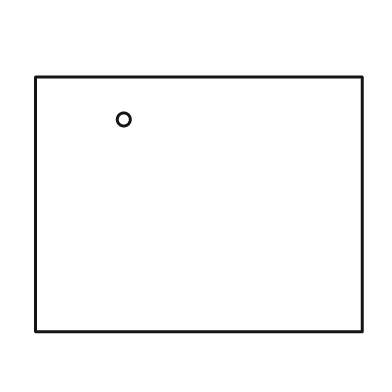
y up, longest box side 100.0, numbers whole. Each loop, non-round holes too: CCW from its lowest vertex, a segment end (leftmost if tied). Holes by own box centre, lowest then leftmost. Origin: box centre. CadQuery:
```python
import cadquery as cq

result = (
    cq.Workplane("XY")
    .moveTo(-50.0, -39.0)
    .lineTo(50.0, -39.0)
    .lineTo(50.0, 39.0)
    .lineTo(-50.0, 39.0)
    .close()
    .moveTo(-23.0, 26.0)
    .circle(2.0)
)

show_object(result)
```